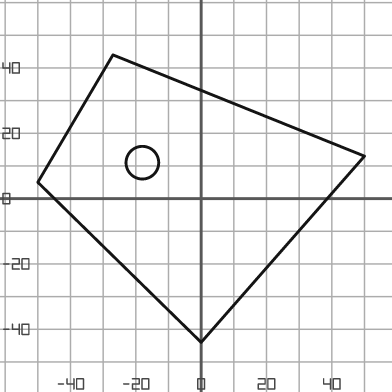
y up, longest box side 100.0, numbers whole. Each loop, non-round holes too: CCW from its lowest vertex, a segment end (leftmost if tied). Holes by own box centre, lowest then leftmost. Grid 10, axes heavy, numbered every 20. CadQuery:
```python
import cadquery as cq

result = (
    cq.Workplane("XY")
    .moveTo(0.0, -44.0)
    .lineTo(50.0, 13.0)
    .lineTo(-27.0, 44.0)
    .lineTo(-50.0, 5.0)
    .close()
    .moveTo(-18.0, 11.0)
    .circle(5.0)
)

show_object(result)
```